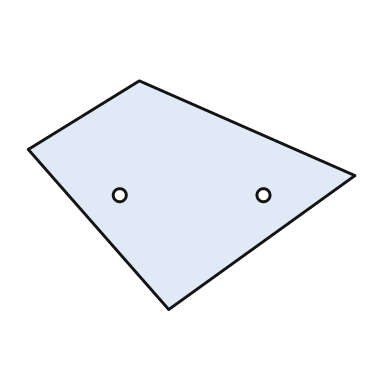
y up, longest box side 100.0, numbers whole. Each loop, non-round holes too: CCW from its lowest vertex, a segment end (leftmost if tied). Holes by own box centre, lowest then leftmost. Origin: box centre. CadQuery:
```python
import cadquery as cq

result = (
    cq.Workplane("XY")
    .moveTo(-7.0, -35.0)
    .lineTo(50.0, 6.0)
    .lineTo(-16.0, 35.0)
    .lineTo(-50.0, 14.0)
    .close()
    .moveTo(-22.0, 0.0)
    .circle(2.0)
    .moveTo(22.0, 0.0)
    .circle(2.0)
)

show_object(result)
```